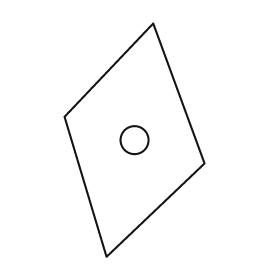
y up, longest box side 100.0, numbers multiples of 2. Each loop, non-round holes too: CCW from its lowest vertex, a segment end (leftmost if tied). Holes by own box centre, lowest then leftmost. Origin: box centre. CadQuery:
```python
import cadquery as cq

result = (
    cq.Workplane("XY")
    .moveTo(-12.0, -50.0)
    .lineTo(30.0, -10.0)
    .lineTo(8.0, 50.0)
    .lineTo(-30.0, 10.0)
    .close()
    .moveTo(0.0, 0.0)
    .circle(6.0)
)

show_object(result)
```